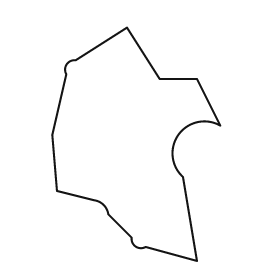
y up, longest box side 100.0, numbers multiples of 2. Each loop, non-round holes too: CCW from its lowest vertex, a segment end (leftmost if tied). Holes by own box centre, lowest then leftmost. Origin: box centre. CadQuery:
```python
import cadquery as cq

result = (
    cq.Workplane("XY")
    .moveTo(26.0, -50.0)
    .lineTo(20.0, -14.0)
    .threePointArc((18.0, 4.0), (36.0, 8.0))
    .lineTo(26.0, 28.0)
    .lineTo(10.0, 28.0)
    .lineTo(-4.0, 50.0)
    .lineTo(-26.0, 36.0)
    .threePointArc((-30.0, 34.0), (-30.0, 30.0))
    .lineTo(-36.0, 4.0)
    .lineTo(-34.0, -20.0)
    .lineTo(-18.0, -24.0)
    .threePointArc((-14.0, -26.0), (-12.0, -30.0))
    .lineTo(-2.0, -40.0)
    .threePointArc((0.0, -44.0), (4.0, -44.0))
    .close()
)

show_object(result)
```